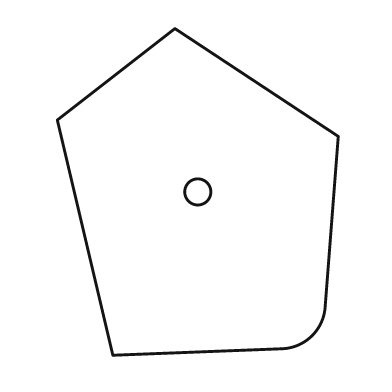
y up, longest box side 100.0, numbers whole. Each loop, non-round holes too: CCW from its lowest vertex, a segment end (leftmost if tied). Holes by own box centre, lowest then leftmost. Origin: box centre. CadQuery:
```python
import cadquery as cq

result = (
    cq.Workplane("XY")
    .moveTo(-26.0, -50.0)
    .lineTo(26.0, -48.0)
    .threePointArc((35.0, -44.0), (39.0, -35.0))
    .lineTo(43.0, 17.0)
    .lineTo(-7.0, 50.0)
    .lineTo(-43.0, 22.0)
    .close()
    .moveTo(0.0, 0.0)
    .circle(4.0)
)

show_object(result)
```